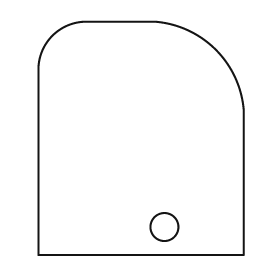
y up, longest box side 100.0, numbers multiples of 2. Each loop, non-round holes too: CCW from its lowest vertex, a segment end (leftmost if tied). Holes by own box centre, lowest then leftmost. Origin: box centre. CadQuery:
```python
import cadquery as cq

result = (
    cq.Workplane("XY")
    .moveTo(-44.0, -50.0)
    .lineTo(44.0, -50.0)
    .lineTo(44.0, 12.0)
    .threePointArc((32.0, 38.0), (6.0, 50.0))
    .lineTo(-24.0, 50.0)
    .threePointArc((-38.0, 44.0), (-44.0, 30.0))
    .close()
    .moveTo(10.0, -38.0)
    .circle(6.0)
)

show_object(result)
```